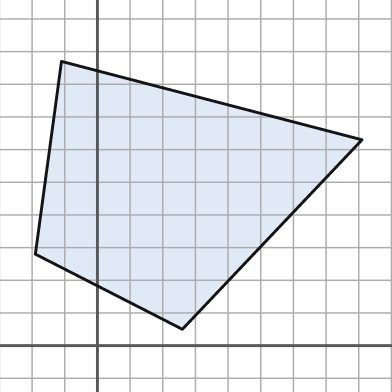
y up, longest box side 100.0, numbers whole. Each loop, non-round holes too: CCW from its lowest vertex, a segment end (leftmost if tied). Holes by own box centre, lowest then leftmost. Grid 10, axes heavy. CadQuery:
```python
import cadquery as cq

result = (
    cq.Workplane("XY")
    .moveTo(26.0, 5.0)
    .lineTo(81.0, 63.0)
    .lineTo(-11.0, 87.0)
    .lineTo(-19.0, 28.0)
    .close()
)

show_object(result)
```